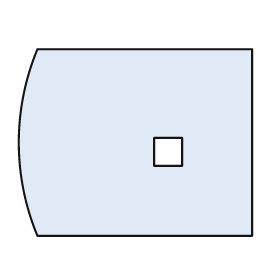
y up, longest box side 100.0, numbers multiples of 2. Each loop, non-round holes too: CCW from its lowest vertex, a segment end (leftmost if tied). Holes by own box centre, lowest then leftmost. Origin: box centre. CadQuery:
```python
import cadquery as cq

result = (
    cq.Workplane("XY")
    .moveTo(-42.0, -40.0)
    .lineTo(50.0, -40.0)
    .lineTo(50.0, 40.0)
    .lineTo(-42.0, 40.0)
    .threePointArc((-50.0, 0.0), (-42.0, -40.0))
    .close()
    .moveTo(8.0, -10.0)
    .lineTo(20.0, -10.0)
    .lineTo(20.0, 2.0)
    .lineTo(8.0, 2.0)
    .close()
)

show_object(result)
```